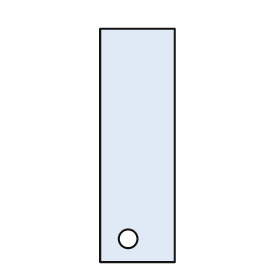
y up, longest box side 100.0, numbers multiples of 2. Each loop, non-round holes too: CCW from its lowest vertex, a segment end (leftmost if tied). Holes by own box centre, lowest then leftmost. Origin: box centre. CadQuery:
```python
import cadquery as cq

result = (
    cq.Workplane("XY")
    .moveTo(-16.0, -50.0)
    .lineTo(16.0, -50.0)
    .lineTo(16.0, 50.0)
    .lineTo(-16.0, 50.0)
    .close()
    .moveTo(-4.0, -40.0)
    .circle(4.0)
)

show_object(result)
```